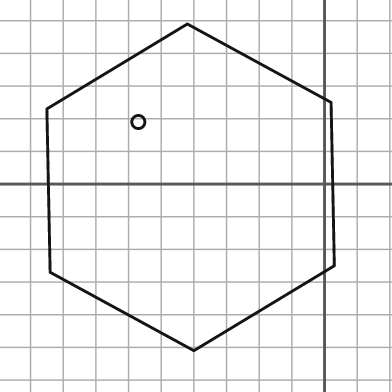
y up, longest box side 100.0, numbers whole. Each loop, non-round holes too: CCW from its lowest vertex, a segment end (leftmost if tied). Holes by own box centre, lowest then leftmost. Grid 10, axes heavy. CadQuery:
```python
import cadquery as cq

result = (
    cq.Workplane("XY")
    .moveTo(-40.0, -51.0)
    .lineTo(3.0, -25.0)
    .lineTo(2.0, 25.0)
    .lineTo(-42.0, 49.0)
    .lineTo(-85.0, 23.0)
    .lineTo(-84.0, -27.0)
    .close()
    .moveTo(-57.0, 19.0)
    .circle(2.0)
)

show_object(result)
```